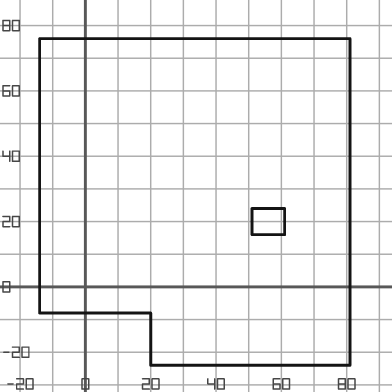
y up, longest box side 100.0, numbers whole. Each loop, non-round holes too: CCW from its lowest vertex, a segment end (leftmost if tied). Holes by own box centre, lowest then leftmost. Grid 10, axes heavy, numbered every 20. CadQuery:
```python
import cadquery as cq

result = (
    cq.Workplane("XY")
    .moveTo(20.0, -24.0)
    .lineTo(81.0, -24.0)
    .lineTo(81.0, 76.0)
    .lineTo(-14.0, 76.0)
    .lineTo(-14.0, -8.0)
    .lineTo(20.0, -8.0)
    .close()
    .moveTo(51.0, 16.0)
    .lineTo(61.0, 16.0)
    .lineTo(61.0, 24.0)
    .lineTo(51.0, 24.0)
    .close()
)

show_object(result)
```